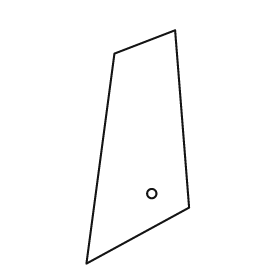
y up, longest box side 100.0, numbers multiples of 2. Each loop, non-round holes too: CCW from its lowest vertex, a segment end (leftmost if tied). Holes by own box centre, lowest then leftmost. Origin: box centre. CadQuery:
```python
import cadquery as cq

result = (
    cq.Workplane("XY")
    .moveTo(-22.0, -50.0)
    .lineTo(22.0, -26.0)
    .lineTo(16.0, 50.0)
    .lineTo(-10.0, 40.0)
    .close()
    .moveTo(6.0, -20.0)
    .circle(2.0)
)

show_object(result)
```